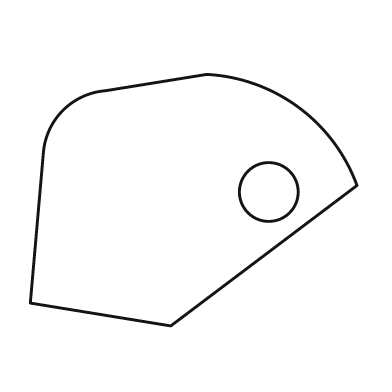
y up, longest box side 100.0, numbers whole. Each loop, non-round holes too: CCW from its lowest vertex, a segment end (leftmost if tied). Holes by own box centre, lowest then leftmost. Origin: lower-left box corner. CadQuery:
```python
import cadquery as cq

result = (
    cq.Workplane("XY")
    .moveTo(43.0, 0.0)
    .lineTo(100.0, 43.0)
    .threePointArc((82.0, 67.0), (54.0, 77.0))
    .lineTo(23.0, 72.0)
    .threePointArc((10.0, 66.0), (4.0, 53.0))
    .lineTo(0.0, 7.0)
    .close()
    .moveTo(73.0, 41.0)
    .circle(9.0)
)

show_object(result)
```